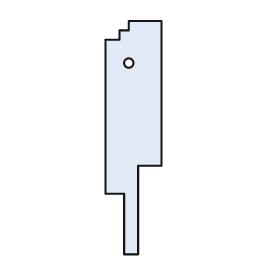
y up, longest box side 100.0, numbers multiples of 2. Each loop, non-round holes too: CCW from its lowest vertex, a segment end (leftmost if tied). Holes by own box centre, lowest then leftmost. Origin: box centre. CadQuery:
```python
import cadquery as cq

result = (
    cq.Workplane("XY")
    .moveTo(-4.0, -50.0)
    .lineTo(2.0, -50.0)
    .lineTo(2.0, -12.0)
    .lineTo(12.0, -12.0)
    .lineTo(12.0, 50.0)
    .lineTo(-2.0, 50.0)
    .lineTo(-2.0, 46.0)
    .lineTo(-6.0, 46.0)
    .lineTo(-6.0, 42.0)
    .lineTo(-12.0, 42.0)
    .lineTo(-12.0, -24.0)
    .lineTo(-4.0, -24.0)
    .close()
    .moveTo(-2.0, 32.0)
    .circle(2.0)
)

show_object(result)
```